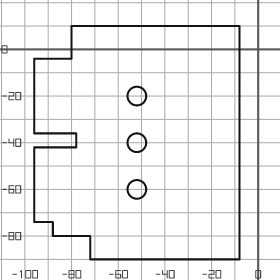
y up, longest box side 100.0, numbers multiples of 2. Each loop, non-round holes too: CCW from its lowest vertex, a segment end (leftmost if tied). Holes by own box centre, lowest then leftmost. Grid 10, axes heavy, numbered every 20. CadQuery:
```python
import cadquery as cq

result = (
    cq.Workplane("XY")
    .moveTo(-72.0, -90.0)
    .lineTo(-8.0, -90.0)
    .lineTo(-8.0, 10.0)
    .lineTo(-80.0, 10.0)
    .lineTo(-80.0, -4.0)
    .lineTo(-96.0, -4.0)
    .lineTo(-96.0, -36.0)
    .lineTo(-78.0, -36.0)
    .lineTo(-78.0, -42.0)
    .lineTo(-96.0, -42.0)
    .lineTo(-96.0, -74.0)
    .lineTo(-88.0, -74.0)
    .lineTo(-88.0, -80.0)
    .lineTo(-72.0, -80.0)
    .close()
    .moveTo(-52.0, -60.0)
    .circle(4.0)
    .moveTo(-52.0, -40.0)
    .circle(4.0)
    .moveTo(-52.0, -20.0)
    .circle(4.0)
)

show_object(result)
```